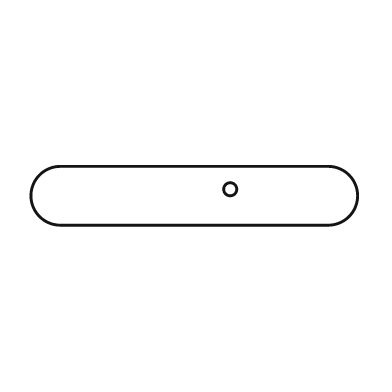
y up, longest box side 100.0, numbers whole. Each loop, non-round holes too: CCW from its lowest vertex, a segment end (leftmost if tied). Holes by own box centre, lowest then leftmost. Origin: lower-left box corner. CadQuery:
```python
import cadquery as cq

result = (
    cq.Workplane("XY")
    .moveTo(9.0, 0.0)
    .lineTo(91.0, 0.0)
    .threePointArc((100.0, 9.0), (91.0, 18.0))
    .lineTo(9.0, 18.0)
    .threePointArc((0.0, 9.0), (9.0, 0.0))
    .close()
    .moveTo(61.0, 11.0)
    .circle(2.0)
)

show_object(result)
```